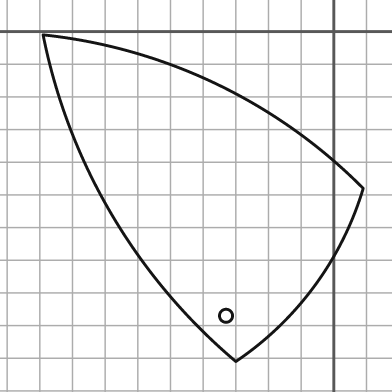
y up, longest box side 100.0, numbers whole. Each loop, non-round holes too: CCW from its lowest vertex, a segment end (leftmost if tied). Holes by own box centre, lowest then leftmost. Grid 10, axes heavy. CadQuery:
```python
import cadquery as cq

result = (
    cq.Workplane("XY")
    .moveTo(-30.0, -101.0)
    .threePointArc((-6.0, -78.0), (9.0, -48.0))
    .threePointArc((-36.0, -16.0), (-89.0, -1.0))
    .threePointArc((-68.0, -56.0), (-30.0, -101.0))
    .close()
    .moveTo(-33.0, -87.0)
    .circle(2.0)
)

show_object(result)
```